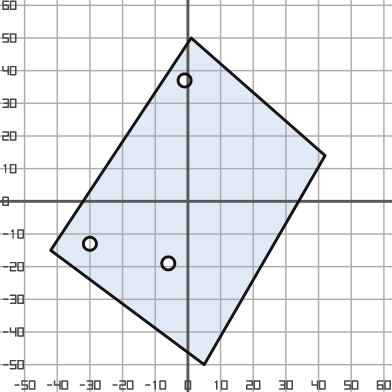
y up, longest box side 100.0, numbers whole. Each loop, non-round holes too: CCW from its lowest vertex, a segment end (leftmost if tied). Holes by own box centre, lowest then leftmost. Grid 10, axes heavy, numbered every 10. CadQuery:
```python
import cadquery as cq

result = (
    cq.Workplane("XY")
    .moveTo(5.0, -50.0)
    .lineTo(42.0, 14.0)
    .lineTo(1.0, 50.0)
    .lineTo(-42.0, -15.0)
    .close()
    .moveTo(-6.0, -19.0)
    .circle(2.0)
    .moveTo(-30.0, -13.0)
    .circle(2.0)
    .moveTo(-1.0, 37.0)
    .circle(2.0)
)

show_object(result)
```